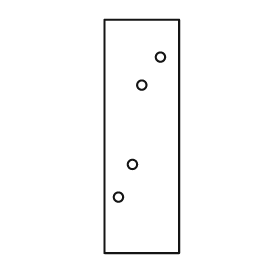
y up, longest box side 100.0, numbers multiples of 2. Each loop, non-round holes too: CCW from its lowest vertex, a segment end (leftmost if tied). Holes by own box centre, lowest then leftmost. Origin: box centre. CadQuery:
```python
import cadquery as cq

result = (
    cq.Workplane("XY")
    .moveTo(-16.0, -50.0)
    .lineTo(16.0, -50.0)
    .lineTo(16.0, 50.0)
    .lineTo(-16.0, 50.0)
    .close()
    .moveTo(-10.0, -26.0)
    .circle(2.0)
    .moveTo(-4.0, -12.0)
    .circle(2.0)
    .moveTo(0.0, 22.0)
    .circle(2.0)
    .moveTo(8.0, 34.0)
    .circle(2.0)
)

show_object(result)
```